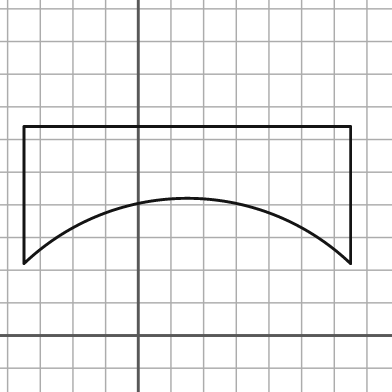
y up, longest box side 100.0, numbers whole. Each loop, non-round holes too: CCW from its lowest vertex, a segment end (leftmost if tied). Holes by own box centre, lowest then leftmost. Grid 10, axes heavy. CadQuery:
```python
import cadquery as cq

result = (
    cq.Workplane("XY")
    .moveTo(-35.0, 22.0)
    .threePointArc((15.0, 42.0), (65.0, 22.0))
    .lineTo(65.0, 64.0)
    .lineTo(-35.0, 64.0)
    .close()
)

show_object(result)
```